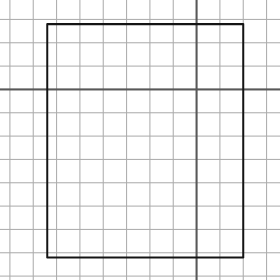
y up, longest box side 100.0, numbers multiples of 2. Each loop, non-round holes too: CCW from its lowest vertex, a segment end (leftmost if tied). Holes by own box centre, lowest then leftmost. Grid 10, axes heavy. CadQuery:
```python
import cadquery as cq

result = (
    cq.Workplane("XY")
    .moveTo(-64.0, -72.0)
    .lineTo(20.0, -72.0)
    .lineTo(20.0, 28.0)
    .lineTo(-64.0, 28.0)
    .close()
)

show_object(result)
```